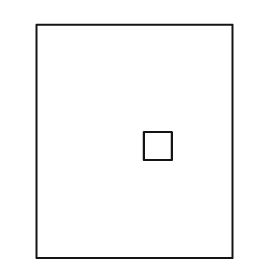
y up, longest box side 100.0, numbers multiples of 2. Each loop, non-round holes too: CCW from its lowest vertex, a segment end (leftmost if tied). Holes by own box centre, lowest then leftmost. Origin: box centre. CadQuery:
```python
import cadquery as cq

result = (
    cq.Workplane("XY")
    .moveTo(-42.0, -50.0)
    .lineTo(42.0, -50.0)
    .lineTo(42.0, 50.0)
    .lineTo(-42.0, 50.0)
    .close()
    .moveTo(4.0, -8.0)
    .lineTo(16.0, -8.0)
    .lineTo(16.0, 4.0)
    .lineTo(4.0, 4.0)
    .close()
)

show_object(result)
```